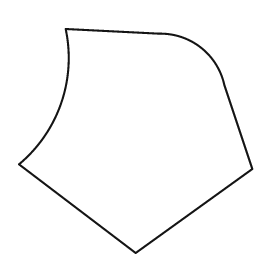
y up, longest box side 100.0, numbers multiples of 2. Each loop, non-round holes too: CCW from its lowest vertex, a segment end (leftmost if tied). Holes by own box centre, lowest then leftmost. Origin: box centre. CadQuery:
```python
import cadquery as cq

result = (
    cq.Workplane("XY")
    .moveTo(0.0, -48.0)
    .lineTo(50.0, -12.0)
    .lineTo(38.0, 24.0)
    .threePointArc((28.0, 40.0), (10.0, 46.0))
    .lineTo(-30.0, 48.0)
    .threePointArc((-32.0, 16.0), (-50.0, -10.0))
    .close()
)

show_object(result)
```